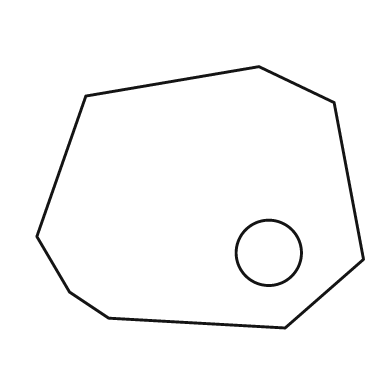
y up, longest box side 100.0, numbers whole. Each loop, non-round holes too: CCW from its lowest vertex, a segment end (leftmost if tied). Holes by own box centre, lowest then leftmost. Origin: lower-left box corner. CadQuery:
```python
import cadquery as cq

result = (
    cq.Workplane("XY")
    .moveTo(76.0, 0.0)
    .lineTo(100.0, 21.0)
    .lineTo(91.0, 69.0)
    .lineTo(68.0, 80.0)
    .lineTo(15.0, 71.0)
    .lineTo(0.0, 28.0)
    .lineTo(10.0, 11.0)
    .lineTo(22.0, 3.0)
    .close()
    .moveTo(71.0, 23.0)
    .circle(10.0)
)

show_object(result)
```